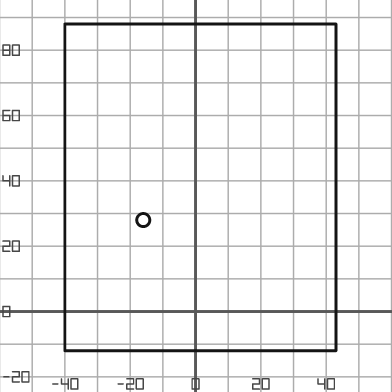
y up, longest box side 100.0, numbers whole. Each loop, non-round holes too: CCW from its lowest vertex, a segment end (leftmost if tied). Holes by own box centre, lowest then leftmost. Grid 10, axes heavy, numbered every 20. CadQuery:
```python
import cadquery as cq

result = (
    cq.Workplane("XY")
    .moveTo(-40.0, -12.0)
    .lineTo(43.0, -12.0)
    .lineTo(43.0, 88.0)
    .lineTo(-40.0, 88.0)
    .close()
    .moveTo(-16.0, 28.0)
    .circle(2.0)
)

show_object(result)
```